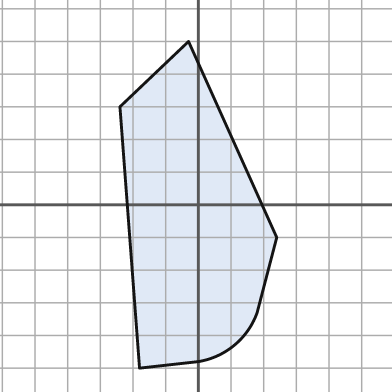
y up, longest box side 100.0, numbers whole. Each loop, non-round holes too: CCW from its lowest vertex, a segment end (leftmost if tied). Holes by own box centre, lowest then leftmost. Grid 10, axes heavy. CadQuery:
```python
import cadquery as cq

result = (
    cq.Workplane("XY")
    .moveTo(-18.0, -50.0)
    .lineTo(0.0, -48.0)
    .threePointArc((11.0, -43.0), (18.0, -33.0))
    .lineTo(24.0, -10.0)
    .lineTo(-3.0, 50.0)
    .lineTo(-24.0, 30.0)
    .close()
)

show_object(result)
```